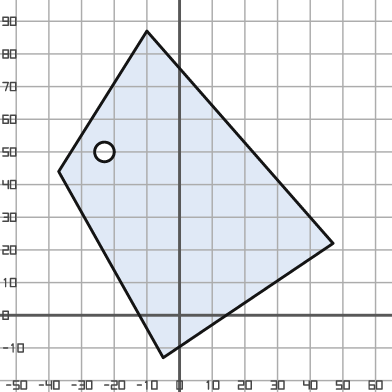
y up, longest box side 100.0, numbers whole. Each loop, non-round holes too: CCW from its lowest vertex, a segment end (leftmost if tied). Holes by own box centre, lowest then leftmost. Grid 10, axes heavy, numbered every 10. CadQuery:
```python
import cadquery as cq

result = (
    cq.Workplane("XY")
    .moveTo(-5.0, -13.0)
    .lineTo(47.0, 22.0)
    .lineTo(-10.0, 87.0)
    .lineTo(-37.0, 44.0)
    .close()
    .moveTo(-23.0, 50.0)
    .circle(3.0)
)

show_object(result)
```